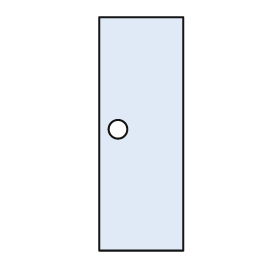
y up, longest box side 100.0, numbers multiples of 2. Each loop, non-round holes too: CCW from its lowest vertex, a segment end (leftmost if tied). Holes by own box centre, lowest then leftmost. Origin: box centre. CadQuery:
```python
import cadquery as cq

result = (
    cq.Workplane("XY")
    .moveTo(-18.0, -50.0)
    .lineTo(18.0, -50.0)
    .lineTo(18.0, 50.0)
    .lineTo(-18.0, 50.0)
    .close()
    .moveTo(-10.0, 2.0)
    .circle(4.0)
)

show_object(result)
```